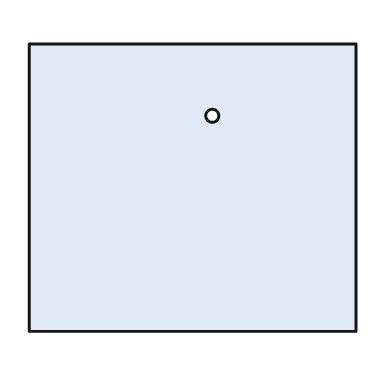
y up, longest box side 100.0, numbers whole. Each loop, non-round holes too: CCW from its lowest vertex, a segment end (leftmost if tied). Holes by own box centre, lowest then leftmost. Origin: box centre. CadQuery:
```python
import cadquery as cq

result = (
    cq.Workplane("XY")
    .moveTo(-50.0, -44.0)
    .lineTo(50.0, -44.0)
    .lineTo(50.0, 44.0)
    .lineTo(-50.0, 44.0)
    .close()
    .moveTo(6.0, 22.0)
    .circle(2.0)
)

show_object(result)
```